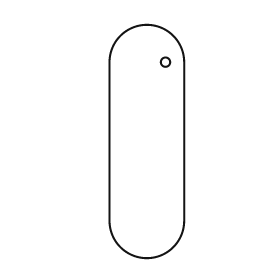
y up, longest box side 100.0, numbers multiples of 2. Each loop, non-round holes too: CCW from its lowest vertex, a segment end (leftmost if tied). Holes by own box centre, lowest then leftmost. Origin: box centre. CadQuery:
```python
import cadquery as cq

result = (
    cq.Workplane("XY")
    .moveTo(-16.0, -34.0)
    .threePointArc((0.0, -50.0), (16.0, -34.0))
    .lineTo(16.0, 34.0)
    .threePointArc((0.0, 50.0), (-16.0, 34.0))
    .close()
    .moveTo(8.0, 34.0)
    .circle(2.0)
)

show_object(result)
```